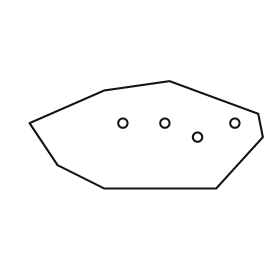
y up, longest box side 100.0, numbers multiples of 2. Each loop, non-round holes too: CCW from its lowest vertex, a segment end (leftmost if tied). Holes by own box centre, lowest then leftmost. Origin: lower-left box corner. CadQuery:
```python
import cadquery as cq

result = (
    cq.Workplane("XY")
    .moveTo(32.0, 0.0)
    .lineTo(80.0, 0.0)
    .lineTo(100.0, 22.0)
    .lineTo(98.0, 32.0)
    .lineTo(60.0, 46.0)
    .lineTo(32.0, 42.0)
    .lineTo(0.0, 28.0)
    .lineTo(12.0, 10.0)
    .close()
    .moveTo(72.0, 22.0)
    .circle(2.0)
    .moveTo(40.0, 28.0)
    .circle(2.0)
    .moveTo(58.0, 28.0)
    .circle(2.0)
    .moveTo(88.0, 28.0)
    .circle(2.0)
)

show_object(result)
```